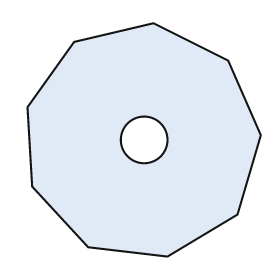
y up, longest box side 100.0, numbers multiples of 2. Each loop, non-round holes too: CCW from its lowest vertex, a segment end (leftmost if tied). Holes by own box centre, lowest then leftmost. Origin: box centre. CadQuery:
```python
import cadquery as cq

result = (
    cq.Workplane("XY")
    .moveTo(10.0, -50.0)
    .lineTo(40.0, -32.0)
    .lineTo(50.0, 2.0)
    .lineTo(36.0, 34.0)
    .lineTo(4.0, 50.0)
    .lineTo(-30.0, 42.0)
    .lineTo(-50.0, 14.0)
    .lineTo(-48.0, -20.0)
    .lineTo(-24.0, -46.0)
    .close()
    .moveTo(0.0, 0.0)
    .circle(10.0)
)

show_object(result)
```